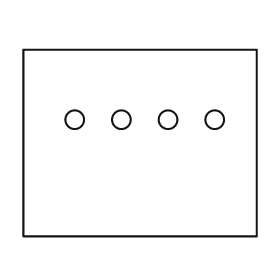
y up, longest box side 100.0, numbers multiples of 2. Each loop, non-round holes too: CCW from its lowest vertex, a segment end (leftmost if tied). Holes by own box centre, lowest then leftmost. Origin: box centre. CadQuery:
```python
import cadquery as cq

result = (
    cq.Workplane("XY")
    .moveTo(-50.0, -40.0)
    .lineTo(50.0, -40.0)
    .lineTo(50.0, 40.0)
    .lineTo(-50.0, 40.0)
    .close()
    .moveTo(-28.0, 10.0)
    .circle(4.0)
    .moveTo(-8.0, 10.0)
    .circle(4.0)
    .moveTo(12.0, 10.0)
    .circle(4.0)
    .moveTo(32.0, 10.0)
    .circle(4.0)
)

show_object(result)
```